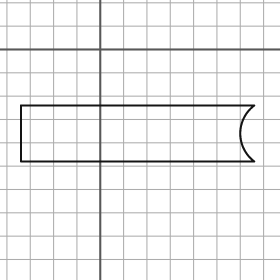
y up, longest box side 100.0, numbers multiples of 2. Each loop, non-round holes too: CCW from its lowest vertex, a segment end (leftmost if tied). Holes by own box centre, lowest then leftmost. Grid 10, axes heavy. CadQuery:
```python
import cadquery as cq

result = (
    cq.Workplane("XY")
    .moveTo(-34.0, -48.0)
    .lineTo(66.0, -48.0)
    .threePointArc((60.0, -36.0), (66.0, -24.0))
    .lineTo(-34.0, -24.0)
    .close()
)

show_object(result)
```